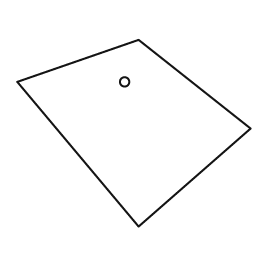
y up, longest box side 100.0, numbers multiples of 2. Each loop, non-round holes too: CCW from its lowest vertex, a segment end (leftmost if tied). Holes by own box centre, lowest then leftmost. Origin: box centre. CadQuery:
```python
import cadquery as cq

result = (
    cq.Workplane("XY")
    .moveTo(2.0, -40.0)
    .lineTo(50.0, 2.0)
    .lineTo(2.0, 40.0)
    .lineTo(-50.0, 22.0)
    .close()
    .moveTo(-4.0, 22.0)
    .circle(2.0)
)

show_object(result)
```